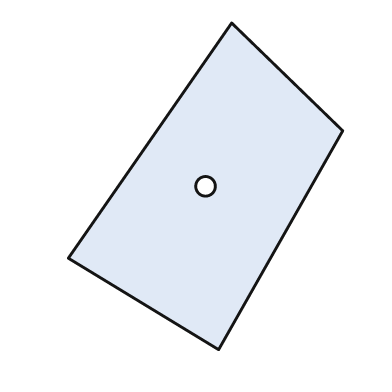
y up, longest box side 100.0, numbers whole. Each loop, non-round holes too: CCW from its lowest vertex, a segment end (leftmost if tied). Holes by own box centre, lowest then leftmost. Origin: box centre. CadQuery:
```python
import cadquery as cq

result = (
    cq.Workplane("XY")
    .moveTo(4.0, -50.0)
    .lineTo(42.0, 17.0)
    .lineTo(8.0, 50.0)
    .lineTo(-42.0, -22.0)
    .close()
    .moveTo(0.0, 0.0)
    .circle(3.0)
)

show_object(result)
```